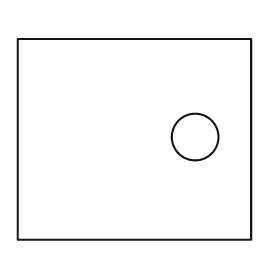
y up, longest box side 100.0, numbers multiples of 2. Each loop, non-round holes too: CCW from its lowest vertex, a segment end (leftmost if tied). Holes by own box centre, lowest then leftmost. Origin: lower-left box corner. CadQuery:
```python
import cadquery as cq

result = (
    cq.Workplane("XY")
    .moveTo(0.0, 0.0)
    .lineTo(100.0, 0.0)
    .lineTo(100.0, 86.0)
    .lineTo(0.0, 86.0)
    .close()
    .moveTo(76.0, 44.0)
    .circle(10.0)
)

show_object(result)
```